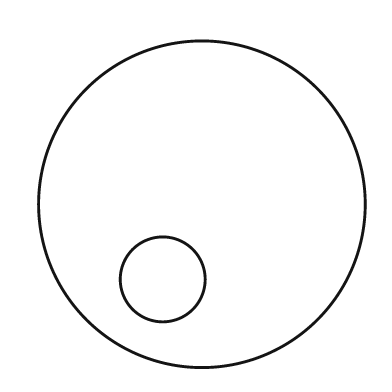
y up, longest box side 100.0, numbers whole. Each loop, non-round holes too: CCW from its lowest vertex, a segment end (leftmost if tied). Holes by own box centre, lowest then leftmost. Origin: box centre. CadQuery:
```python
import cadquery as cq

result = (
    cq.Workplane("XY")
    .moveTo(0.0, 0.0)
    .circle(50.0)
    .moveTo(-12.0, -23.0)
    .circle(13.0)
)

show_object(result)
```